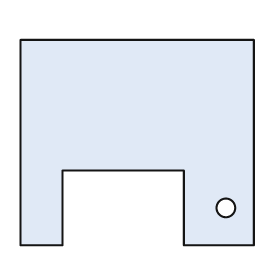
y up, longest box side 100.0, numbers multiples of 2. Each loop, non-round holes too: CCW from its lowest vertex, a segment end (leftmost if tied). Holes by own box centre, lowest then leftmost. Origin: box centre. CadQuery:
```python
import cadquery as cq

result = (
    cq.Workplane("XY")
    .moveTo(-50.0, -44.0)
    .lineTo(-32.0, -44.0)
    .lineTo(-32.0, -12.0)
    .lineTo(20.0, -12.0)
    .lineTo(20.0, -44.0)
    .lineTo(50.0, -44.0)
    .lineTo(50.0, 44.0)
    .lineTo(-50.0, 44.0)
    .close()
    .moveTo(38.0, -28.0)
    .circle(4.0)
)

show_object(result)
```